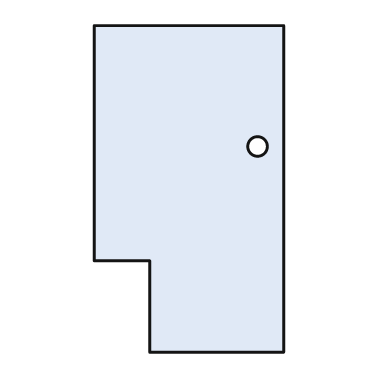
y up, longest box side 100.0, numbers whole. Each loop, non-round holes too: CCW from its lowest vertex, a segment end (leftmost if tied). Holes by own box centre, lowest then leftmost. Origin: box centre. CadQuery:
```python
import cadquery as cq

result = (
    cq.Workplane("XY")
    .moveTo(-12.0, -50.0)
    .lineTo(29.0, -50.0)
    .lineTo(29.0, 50.0)
    .lineTo(-29.0, 50.0)
    .lineTo(-29.0, -22.0)
    .lineTo(-12.0, -22.0)
    .close()
    .moveTo(21.0, 13.0)
    .circle(3.0)
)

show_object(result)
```